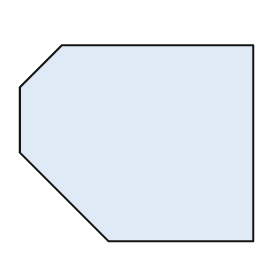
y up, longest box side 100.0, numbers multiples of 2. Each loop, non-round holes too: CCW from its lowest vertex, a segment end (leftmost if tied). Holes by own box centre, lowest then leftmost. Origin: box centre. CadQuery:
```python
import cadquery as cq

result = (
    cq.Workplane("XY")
    .moveTo(-12.0, -42.0)
    .lineTo(50.0, -42.0)
    .lineTo(50.0, 42.0)
    .lineTo(-32.0, 42.0)
    .lineTo(-50.0, 24.0)
    .lineTo(-50.0, -4.0)
    .close()
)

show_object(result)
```